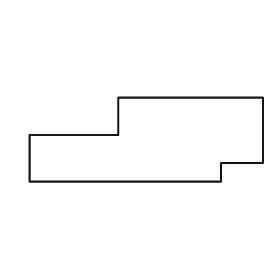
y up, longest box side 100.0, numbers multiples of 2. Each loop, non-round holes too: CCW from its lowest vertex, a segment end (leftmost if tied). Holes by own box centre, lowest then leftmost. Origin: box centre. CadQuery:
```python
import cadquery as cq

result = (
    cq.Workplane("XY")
    .moveTo(-50.0, -18.0)
    .lineTo(32.0, -18.0)
    .lineTo(32.0, -10.0)
    .lineTo(50.0, -10.0)
    .lineTo(50.0, 18.0)
    .lineTo(-12.0, 18.0)
    .lineTo(-12.0, 2.0)
    .lineTo(-50.0, 2.0)
    .close()
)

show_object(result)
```